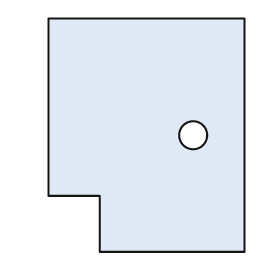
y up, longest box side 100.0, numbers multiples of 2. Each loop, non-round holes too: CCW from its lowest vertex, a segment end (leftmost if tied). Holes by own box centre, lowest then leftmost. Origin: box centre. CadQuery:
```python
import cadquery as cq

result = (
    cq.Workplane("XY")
    .moveTo(-20.0, -50.0)
    .lineTo(42.0, -50.0)
    .lineTo(42.0, 50.0)
    .lineTo(-42.0, 50.0)
    .lineTo(-42.0, -26.0)
    .lineTo(-20.0, -26.0)
    .close()
    .moveTo(20.0, 0.0)
    .circle(6.0)
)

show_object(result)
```